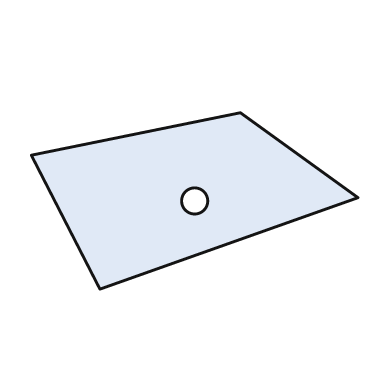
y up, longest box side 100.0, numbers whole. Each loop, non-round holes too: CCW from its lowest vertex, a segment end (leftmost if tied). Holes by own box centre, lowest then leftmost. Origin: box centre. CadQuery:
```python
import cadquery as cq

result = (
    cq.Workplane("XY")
    .moveTo(-29.0, -27.0)
    .lineTo(50.0, 1.0)
    .lineTo(14.0, 27.0)
    .lineTo(-50.0, 14.0)
    .close()
    .moveTo(0.0, 0.0)
    .circle(4.0)
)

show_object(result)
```